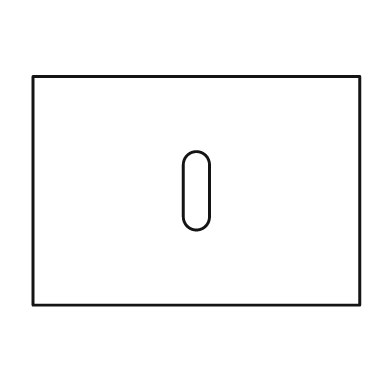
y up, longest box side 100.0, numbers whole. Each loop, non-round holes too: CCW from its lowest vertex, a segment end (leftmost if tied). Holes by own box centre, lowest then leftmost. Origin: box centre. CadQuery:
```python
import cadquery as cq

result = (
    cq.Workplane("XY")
    .moveTo(-50.0, -35.0)
    .lineTo(50.0, -35.0)
    .lineTo(50.0, 35.0)
    .lineTo(-50.0, 35.0)
    .close()
    .moveTo(-4.0, -8.0)
    .threePointArc((0.0, -12.0), (4.0, -8.0))
    .lineTo(4.0, 8.0)
    .threePointArc((0.0, 12.0), (-4.0, 8.0))
    .close()
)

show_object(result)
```